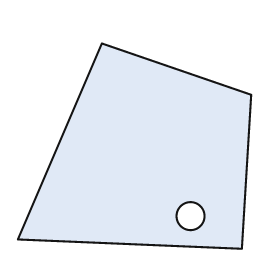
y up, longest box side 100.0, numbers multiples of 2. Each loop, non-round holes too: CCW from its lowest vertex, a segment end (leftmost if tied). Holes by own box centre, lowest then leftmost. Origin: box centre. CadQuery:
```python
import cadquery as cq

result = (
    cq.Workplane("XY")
    .moveTo(46.0, -44.0)
    .lineTo(50.0, 22.0)
    .lineTo(-14.0, 44.0)
    .lineTo(-50.0, -40.0)
    .close()
    .moveTo(24.0, -30.0)
    .circle(6.0)
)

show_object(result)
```